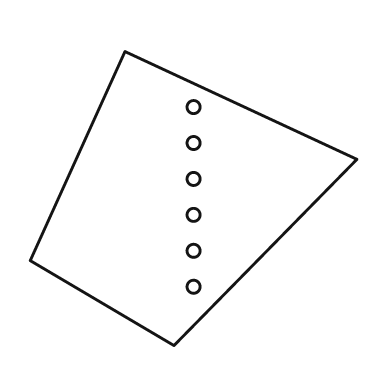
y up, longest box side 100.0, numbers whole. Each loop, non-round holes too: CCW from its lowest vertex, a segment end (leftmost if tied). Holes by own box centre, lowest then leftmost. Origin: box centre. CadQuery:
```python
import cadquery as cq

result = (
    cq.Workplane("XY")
    .moveTo(-6.0, -45.0)
    .lineTo(50.0, 12.0)
    .lineTo(-21.0, 45.0)
    .lineTo(-50.0, -19.0)
    .close()
    .moveTo(0.0, -27.0)
    .circle(2.0)
    .moveTo(0.0, -16.0)
    .circle(2.0)
    .moveTo(0.0, -5.0)
    .circle(2.0)
    .moveTo(0.0, 6.0)
    .circle(2.0)
    .moveTo(0.0, 17.0)
    .circle(2.0)
    .moveTo(0.0, 28.0)
    .circle(2.0)
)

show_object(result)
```